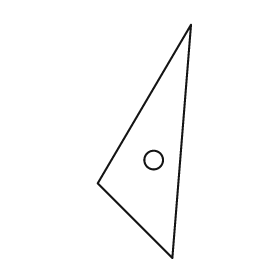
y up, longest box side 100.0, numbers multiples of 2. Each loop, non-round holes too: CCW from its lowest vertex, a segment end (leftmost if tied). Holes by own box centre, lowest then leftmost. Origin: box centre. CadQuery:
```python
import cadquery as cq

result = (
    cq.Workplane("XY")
    .moveTo(12.0, -50.0)
    .lineTo(20.0, 50.0)
    .lineTo(-20.0, -18.0)
    .close()
    .moveTo(4.0, -8.0)
    .circle(4.0)
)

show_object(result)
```